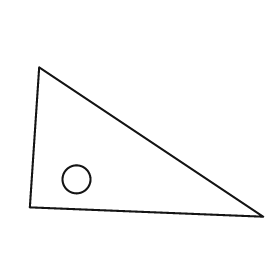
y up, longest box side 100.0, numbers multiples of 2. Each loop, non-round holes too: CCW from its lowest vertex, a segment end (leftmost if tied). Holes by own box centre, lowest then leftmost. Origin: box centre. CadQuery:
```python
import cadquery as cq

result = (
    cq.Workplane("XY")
    .moveTo(50.0, -32.0)
    .lineTo(-46.0, 32.0)
    .lineTo(-50.0, -28.0)
    .close()
    .moveTo(-30.0, -16.0)
    .circle(6.0)
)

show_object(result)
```